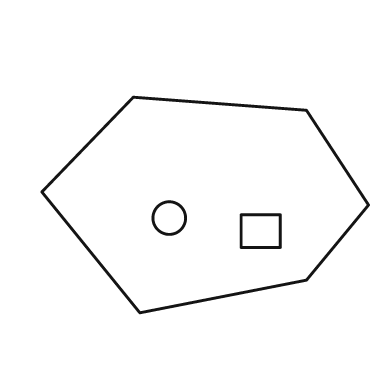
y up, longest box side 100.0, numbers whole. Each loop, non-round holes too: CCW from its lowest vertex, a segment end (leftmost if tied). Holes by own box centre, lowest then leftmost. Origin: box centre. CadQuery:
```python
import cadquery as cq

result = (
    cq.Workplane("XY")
    .moveTo(-20.0, -33.0)
    .lineTo(31.0, -23.0)
    .lineTo(50.0, 0.0)
    .lineTo(31.0, 29.0)
    .lineTo(-22.0, 33.0)
    .lineTo(-50.0, 4.0)
    .close()
    .moveTo(11.0, -13.0)
    .lineTo(23.0, -13.0)
    .lineTo(23.0, -3.0)
    .lineTo(11.0, -3.0)
    .close()
    .moveTo(-11.0, -4.0)
    .circle(5.0)
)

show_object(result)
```